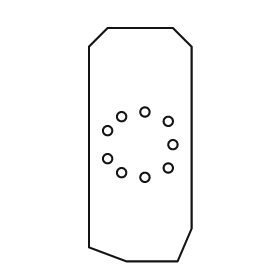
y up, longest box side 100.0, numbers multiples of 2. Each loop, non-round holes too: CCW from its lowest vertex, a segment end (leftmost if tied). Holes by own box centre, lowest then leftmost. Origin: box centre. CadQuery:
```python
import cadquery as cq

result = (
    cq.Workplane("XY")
    .moveTo(-6.0, -50.0)
    .lineTo(16.0, -50.0)
    .lineTo(22.0, -36.0)
    .lineTo(22.0, 42.0)
    .lineTo(14.0, 50.0)
    .lineTo(-14.0, 50.0)
    .lineTo(-22.0, 42.0)
    .lineTo(-22.0, -44.0)
    .close()
    .moveTo(2.0, -14.0)
    .circle(2.0)
    .moveTo(-8.0, -12.0)
    .circle(2.0)
    .moveTo(12.0, -10.0)
    .circle(2.0)
    .moveTo(-14.0, -6.0)
    .circle(2.0)
    .moveTo(14.0, 0.0)
    .circle(2.0)
    .moveTo(-14.0, 6.0)
    .circle(2.0)
    .moveTo(12.0, 10.0)
    .circle(2.0)
    .moveTo(-8.0, 12.0)
    .circle(2.0)
    .moveTo(2.0, 14.0)
    .circle(2.0)
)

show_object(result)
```